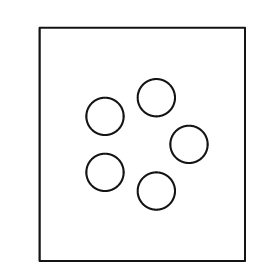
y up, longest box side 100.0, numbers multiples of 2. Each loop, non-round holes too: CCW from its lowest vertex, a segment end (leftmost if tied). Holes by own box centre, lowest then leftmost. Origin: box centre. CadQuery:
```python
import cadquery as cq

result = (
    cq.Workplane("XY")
    .moveTo(-44.0, -50.0)
    .lineTo(44.0, -50.0)
    .lineTo(44.0, 50.0)
    .lineTo(-44.0, 50.0)
    .close()
    .moveTo(6.0, -20.0)
    .circle(8.0)
    .moveTo(-16.0, -12.0)
    .circle(8.0)
    .moveTo(20.0, 0.0)
    .circle(8.0)
    .moveTo(-16.0, 12.0)
    .circle(8.0)
    .moveTo(6.0, 20.0)
    .circle(8.0)
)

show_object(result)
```